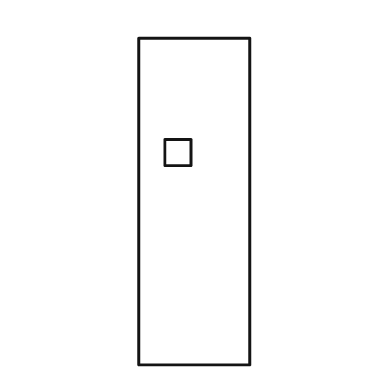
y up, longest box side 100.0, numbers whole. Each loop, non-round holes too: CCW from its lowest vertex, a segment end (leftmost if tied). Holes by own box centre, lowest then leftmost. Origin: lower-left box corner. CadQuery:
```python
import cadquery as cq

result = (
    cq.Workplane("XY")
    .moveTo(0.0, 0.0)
    .lineTo(34.0, 0.0)
    .lineTo(34.0, 100.0)
    .lineTo(0.0, 100.0)
    .close()
    .moveTo(8.0, 61.0)
    .lineTo(16.0, 61.0)
    .lineTo(16.0, 69.0)
    .lineTo(8.0, 69.0)
    .close()
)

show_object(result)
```